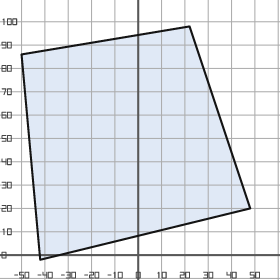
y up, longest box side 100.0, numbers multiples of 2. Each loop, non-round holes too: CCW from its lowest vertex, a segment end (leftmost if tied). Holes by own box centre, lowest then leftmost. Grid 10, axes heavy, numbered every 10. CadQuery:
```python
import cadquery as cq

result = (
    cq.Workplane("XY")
    .moveTo(-42.0, -2.0)
    .lineTo(48.0, 20.0)
    .lineTo(22.0, 98.0)
    .lineTo(-50.0, 86.0)
    .close()
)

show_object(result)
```